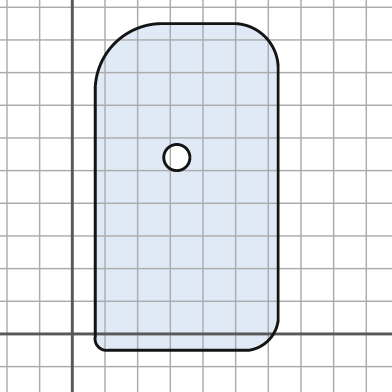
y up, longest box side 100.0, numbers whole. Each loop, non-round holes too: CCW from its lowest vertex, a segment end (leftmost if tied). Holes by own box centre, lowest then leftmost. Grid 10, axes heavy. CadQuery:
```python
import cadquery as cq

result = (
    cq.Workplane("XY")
    .moveTo(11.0, -5.0)
    .lineTo(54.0, -5.0)
    .threePointArc((60.0, -2.0), (63.0, 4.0))
    .lineTo(63.0, 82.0)
    .threePointArc((59.0, 91.0), (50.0, 95.0))
    .lineTo(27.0, 95.0)
    .threePointArc((13.0, 89.0), (7.0, 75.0))
    .lineTo(7.0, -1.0)
    .threePointArc((8.0, -4.0), (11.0, -5.0))
    .close()
    .moveTo(32.0, 54.0)
    .circle(4.0)
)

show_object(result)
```